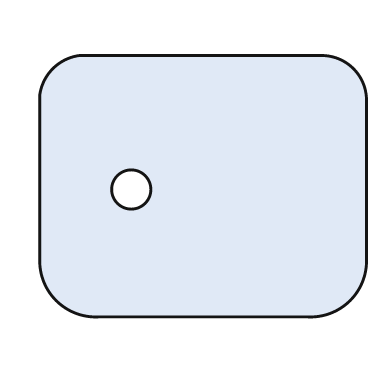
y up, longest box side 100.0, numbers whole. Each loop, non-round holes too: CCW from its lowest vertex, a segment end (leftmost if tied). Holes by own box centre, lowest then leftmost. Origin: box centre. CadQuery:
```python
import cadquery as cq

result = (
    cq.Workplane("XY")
    .moveTo(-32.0, -40.0)
    .lineTo(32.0, -40.0)
    .threePointArc((45.0, -35.0), (50.0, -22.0))
    .lineTo(50.0, 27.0)
    .threePointArc((46.0, 36.0), (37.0, 40.0))
    .lineTo(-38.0, 40.0)
    .threePointArc((-46.0, 36.0), (-50.0, 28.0))
    .lineTo(-50.0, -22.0)
    .threePointArc((-45.0, -35.0), (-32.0, -40.0))
    .close()
    .moveTo(-22.0, -1.0)
    .circle(6.0)
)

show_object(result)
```